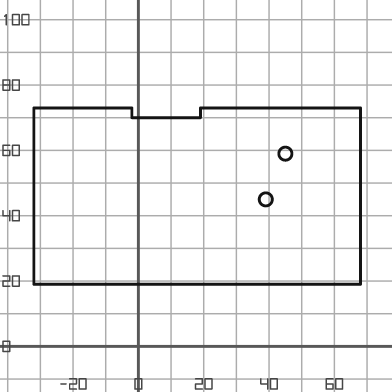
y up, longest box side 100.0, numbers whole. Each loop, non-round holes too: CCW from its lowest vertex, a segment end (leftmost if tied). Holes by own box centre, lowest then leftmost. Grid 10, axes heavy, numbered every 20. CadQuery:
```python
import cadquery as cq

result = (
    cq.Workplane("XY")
    .moveTo(-32.0, 19.0)
    .lineTo(68.0, 19.0)
    .lineTo(68.0, 73.0)
    .lineTo(19.0, 73.0)
    .lineTo(19.0, 70.0)
    .lineTo(-2.0, 70.0)
    .lineTo(-2.0, 73.0)
    .lineTo(-32.0, 73.0)
    .close()
    .moveTo(39.0, 45.0)
    .circle(2.0)
    .moveTo(45.0, 59.0)
    .circle(2.0)
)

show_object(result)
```